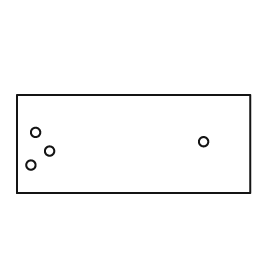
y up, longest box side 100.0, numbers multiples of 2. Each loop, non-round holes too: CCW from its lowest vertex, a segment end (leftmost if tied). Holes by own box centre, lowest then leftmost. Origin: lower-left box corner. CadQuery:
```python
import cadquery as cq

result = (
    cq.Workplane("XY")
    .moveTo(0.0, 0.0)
    .lineTo(100.0, 0.0)
    .lineTo(100.0, 42.0)
    .lineTo(0.0, 42.0)
    .close()
    .moveTo(6.0, 12.0)
    .circle(2.0)
    .moveTo(14.0, 18.0)
    .circle(2.0)
    .moveTo(80.0, 22.0)
    .circle(2.0)
    .moveTo(8.0, 26.0)
    .circle(2.0)
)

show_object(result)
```